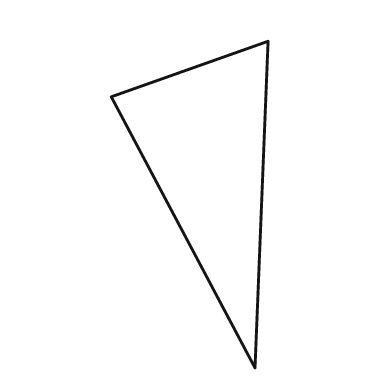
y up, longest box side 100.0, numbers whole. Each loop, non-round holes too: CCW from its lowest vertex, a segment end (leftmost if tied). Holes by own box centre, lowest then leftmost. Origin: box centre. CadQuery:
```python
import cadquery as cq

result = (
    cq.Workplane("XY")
    .moveTo(20.0, -50.0)
    .lineTo(24.0, 50.0)
    .lineTo(-24.0, 33.0)
    .close()
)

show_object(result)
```